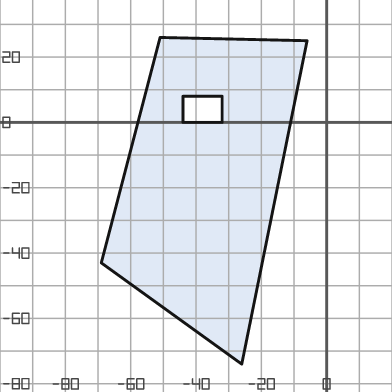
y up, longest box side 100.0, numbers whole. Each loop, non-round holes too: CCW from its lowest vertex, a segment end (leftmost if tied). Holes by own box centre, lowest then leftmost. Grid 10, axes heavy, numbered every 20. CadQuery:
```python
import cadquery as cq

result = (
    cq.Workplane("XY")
    .moveTo(-26.0, -74.0)
    .lineTo(-6.0, 25.0)
    .lineTo(-51.0, 26.0)
    .lineTo(-69.0, -43.0)
    .close()
    .moveTo(-44.0, 0.0)
    .lineTo(-32.0, 0.0)
    .lineTo(-32.0, 8.0)
    .lineTo(-44.0, 8.0)
    .close()
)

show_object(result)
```